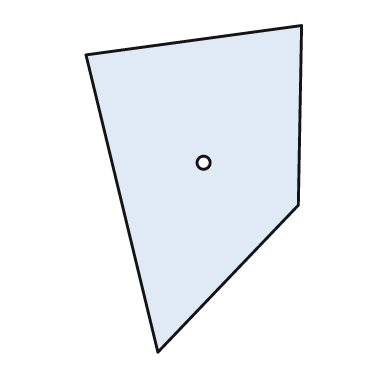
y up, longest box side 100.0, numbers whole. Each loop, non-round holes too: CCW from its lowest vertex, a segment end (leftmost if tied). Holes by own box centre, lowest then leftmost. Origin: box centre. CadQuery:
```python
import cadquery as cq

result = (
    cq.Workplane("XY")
    .moveTo(-11.0, -50.0)
    .lineTo(32.0, -5.0)
    .lineTo(33.0, 50.0)
    .lineTo(-33.0, 41.0)
    .close()
    .moveTo(3.0, 8.0)
    .circle(2.0)
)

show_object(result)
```